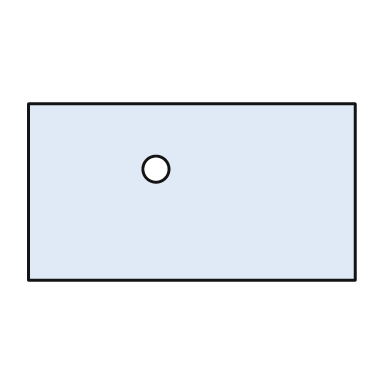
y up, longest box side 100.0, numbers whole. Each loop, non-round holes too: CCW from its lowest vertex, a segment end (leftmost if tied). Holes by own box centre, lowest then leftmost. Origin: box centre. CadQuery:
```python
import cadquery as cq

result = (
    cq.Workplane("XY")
    .moveTo(-50.0, -27.0)
    .lineTo(50.0, -27.0)
    .lineTo(50.0, 27.0)
    .lineTo(-50.0, 27.0)
    .close()
    .moveTo(-11.0, 7.0)
    .circle(4.0)
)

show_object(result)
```